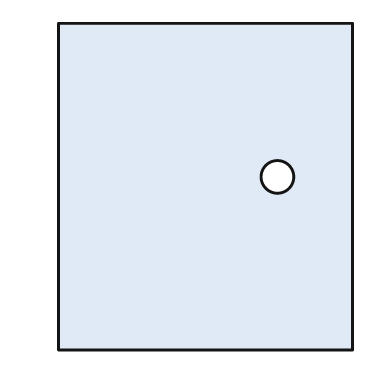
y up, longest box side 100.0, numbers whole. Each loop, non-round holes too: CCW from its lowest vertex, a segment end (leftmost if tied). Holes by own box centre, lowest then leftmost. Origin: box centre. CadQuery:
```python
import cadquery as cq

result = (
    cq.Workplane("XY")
    .moveTo(-45.0, -50.0)
    .lineTo(45.0, -50.0)
    .lineTo(45.0, 50.0)
    .lineTo(-45.0, 50.0)
    .close()
    .moveTo(22.0, 3.0)
    .circle(5.0)
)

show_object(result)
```